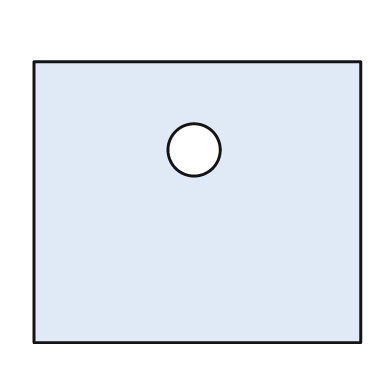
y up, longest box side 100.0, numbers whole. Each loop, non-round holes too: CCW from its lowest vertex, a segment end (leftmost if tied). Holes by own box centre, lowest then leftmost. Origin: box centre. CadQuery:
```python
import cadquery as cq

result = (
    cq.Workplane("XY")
    .moveTo(-50.0, -43.0)
    .lineTo(50.0, -43.0)
    .lineTo(50.0, 43.0)
    .lineTo(-50.0, 43.0)
    .close()
    .moveTo(-1.0, 16.0)
    .circle(8.0)
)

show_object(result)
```